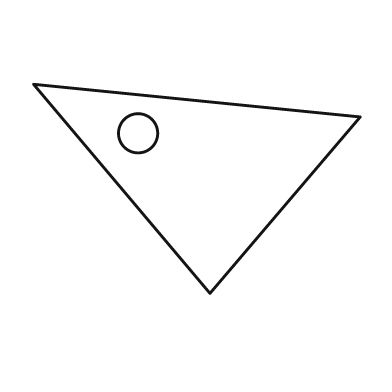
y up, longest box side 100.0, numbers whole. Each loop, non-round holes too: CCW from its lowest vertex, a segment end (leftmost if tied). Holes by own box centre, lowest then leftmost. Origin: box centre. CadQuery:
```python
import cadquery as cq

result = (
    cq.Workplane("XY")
    .moveTo(4.0, -32.0)
    .lineTo(50.0, 22.0)
    .lineTo(-50.0, 32.0)
    .close()
    .moveTo(-18.0, 17.0)
    .circle(6.0)
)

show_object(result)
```